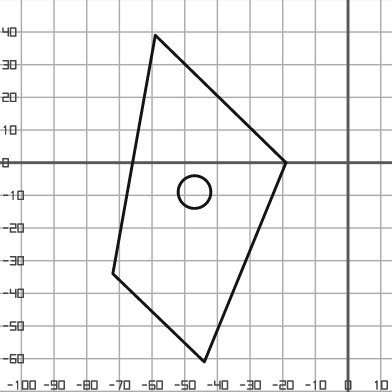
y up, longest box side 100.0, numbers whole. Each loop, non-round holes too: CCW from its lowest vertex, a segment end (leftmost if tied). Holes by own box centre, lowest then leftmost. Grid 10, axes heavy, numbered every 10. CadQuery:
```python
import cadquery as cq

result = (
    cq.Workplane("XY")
    .moveTo(-44.0, -61.0)
    .lineTo(-19.0, 0.0)
    .lineTo(-59.0, 39.0)
    .lineTo(-72.0, -34.0)
    .close()
    .moveTo(-47.0, -9.0)
    .circle(5.0)
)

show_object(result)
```